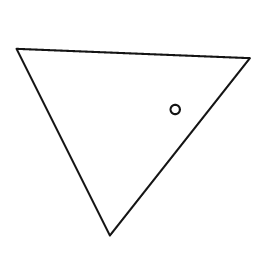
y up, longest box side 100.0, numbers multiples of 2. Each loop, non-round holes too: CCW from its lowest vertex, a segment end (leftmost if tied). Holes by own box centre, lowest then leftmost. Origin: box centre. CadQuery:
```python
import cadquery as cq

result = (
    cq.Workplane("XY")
    .moveTo(-10.0, -40.0)
    .lineTo(50.0, 36.0)
    .lineTo(-50.0, 40.0)
    .close()
    .moveTo(18.0, 14.0)
    .circle(2.0)
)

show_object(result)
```